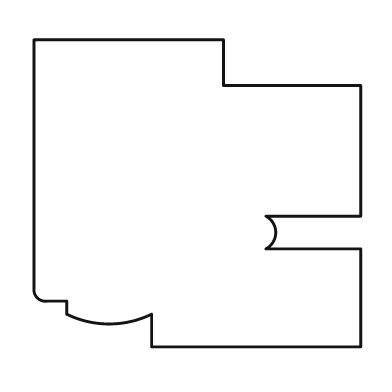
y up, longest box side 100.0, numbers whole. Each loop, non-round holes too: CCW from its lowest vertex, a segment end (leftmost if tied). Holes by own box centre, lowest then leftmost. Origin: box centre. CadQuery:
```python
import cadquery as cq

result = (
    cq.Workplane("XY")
    .moveTo(-14.0, -47.0)
    .lineTo(50.0, -47.0)
    .lineTo(50.0, -17.0)
    .lineTo(21.0, -17.0)
    .threePointArc((24.0, -12.0), (21.0, -7.0))
    .lineTo(50.0, -7.0)
    .lineTo(50.0, 33.0)
    .lineTo(8.0, 33.0)
    .lineTo(8.0, 47.0)
    .lineTo(-50.0, 47.0)
    .lineTo(-50.0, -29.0)
    .threePointArc((-49.0, -32.0), (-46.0, -33.0))
    .lineTo(-40.0, -33.0)
    .lineTo(-40.0, -37.0)
    .threePointArc((-27.0, -40.0), (-14.0, -37.0))
    .close()
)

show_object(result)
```